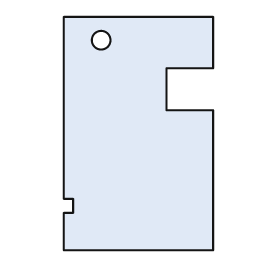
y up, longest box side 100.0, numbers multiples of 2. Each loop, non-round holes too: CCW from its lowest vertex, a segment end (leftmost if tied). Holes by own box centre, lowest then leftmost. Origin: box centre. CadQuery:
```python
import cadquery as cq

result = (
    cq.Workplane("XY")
    .moveTo(-32.0, -50.0)
    .lineTo(32.0, -50.0)
    .lineTo(32.0, 10.0)
    .lineTo(12.0, 10.0)
    .lineTo(12.0, 28.0)
    .lineTo(32.0, 28.0)
    .lineTo(32.0, 50.0)
    .lineTo(-32.0, 50.0)
    .lineTo(-32.0, -28.0)
    .lineTo(-28.0, -28.0)
    .lineTo(-28.0, -34.0)
    .lineTo(-32.0, -34.0)
    .close()
    .moveTo(-16.0, 40.0)
    .circle(4.0)
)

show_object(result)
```